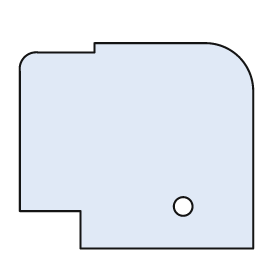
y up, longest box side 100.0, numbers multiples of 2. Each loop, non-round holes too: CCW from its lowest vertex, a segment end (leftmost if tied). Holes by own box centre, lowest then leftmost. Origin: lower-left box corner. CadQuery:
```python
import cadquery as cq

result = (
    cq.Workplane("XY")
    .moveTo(26.0, 0.0)
    .lineTo(100.0, 0.0)
    .lineTo(100.0, 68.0)
    .threePointArc((94.0, 82.0), (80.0, 88.0))
    .lineTo(32.0, 88.0)
    .lineTo(32.0, 84.0)
    .lineTo(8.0, 84.0)
    .threePointArc((2.0, 82.0), (0.0, 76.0))
    .lineTo(0.0, 16.0)
    .lineTo(26.0, 16.0)
    .close()
    .moveTo(70.0, 18.0)
    .circle(4.0)
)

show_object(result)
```